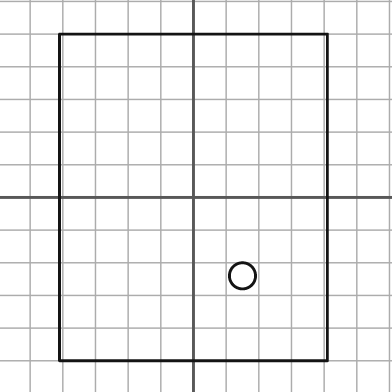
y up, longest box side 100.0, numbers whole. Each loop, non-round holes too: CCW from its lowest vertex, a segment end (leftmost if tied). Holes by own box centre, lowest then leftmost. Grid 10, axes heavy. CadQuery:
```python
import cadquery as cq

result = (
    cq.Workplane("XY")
    .moveTo(-41.0, -50.0)
    .lineTo(41.0, -50.0)
    .lineTo(41.0, 50.0)
    .lineTo(-41.0, 50.0)
    .close()
    .moveTo(15.0, -24.0)
    .circle(4.0)
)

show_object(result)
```